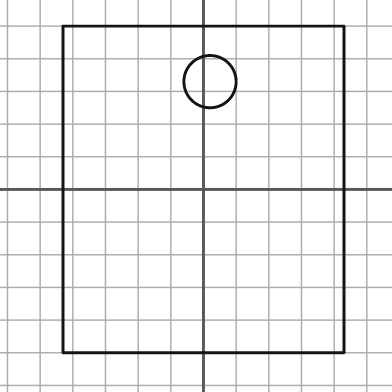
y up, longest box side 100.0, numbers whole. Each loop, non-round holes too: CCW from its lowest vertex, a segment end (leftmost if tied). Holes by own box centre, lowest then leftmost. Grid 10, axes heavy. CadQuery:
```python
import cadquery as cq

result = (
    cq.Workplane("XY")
    .moveTo(-43.0, -50.0)
    .lineTo(43.0, -50.0)
    .lineTo(43.0, 50.0)
    .lineTo(-43.0, 50.0)
    .close()
    .moveTo(2.0, 33.0)
    .circle(8.0)
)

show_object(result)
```